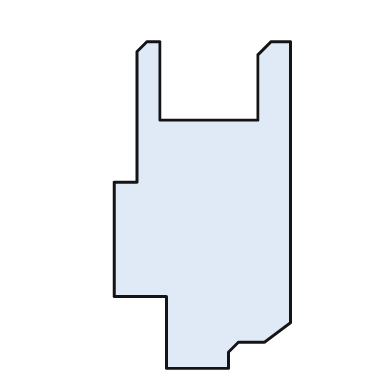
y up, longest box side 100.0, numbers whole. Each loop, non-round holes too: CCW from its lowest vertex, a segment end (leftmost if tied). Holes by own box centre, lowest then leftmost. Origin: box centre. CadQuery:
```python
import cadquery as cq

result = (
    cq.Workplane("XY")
    .moveTo(-11.0, -50.0)
    .lineTo(8.0, -50.0)
    .lineTo(8.0, -45.0)
    .lineTo(11.0, -42.0)
    .lineTo(19.0, -42.0)
    .lineTo(27.0, -36.0)
    .lineTo(27.0, 50.0)
    .lineTo(21.0, 50.0)
    .lineTo(17.0, 46.0)
    .lineTo(17.0, 26.0)
    .lineTo(-13.0, 26.0)
    .lineTo(-13.0, 50.0)
    .lineTo(-17.0, 50.0)
    .lineTo(-20.0, 47.0)
    .lineTo(-20.0, 7.0)
    .lineTo(-27.0, 7.0)
    .lineTo(-27.0, -28.0)
    .lineTo(-11.0, -28.0)
    .close()
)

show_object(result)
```